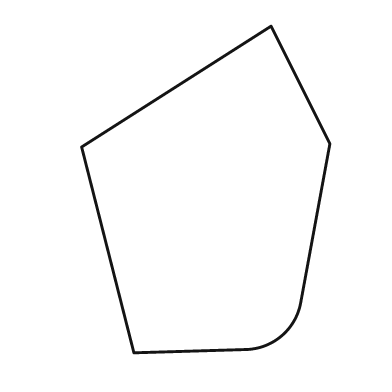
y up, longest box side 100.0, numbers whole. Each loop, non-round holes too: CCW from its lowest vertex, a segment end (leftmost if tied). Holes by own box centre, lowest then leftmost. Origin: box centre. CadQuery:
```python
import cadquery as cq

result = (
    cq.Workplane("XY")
    .moveTo(-22.0, -50.0)
    .lineTo(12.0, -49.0)
    .threePointArc((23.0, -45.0), (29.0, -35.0))
    .lineTo(38.0, 14.0)
    .lineTo(20.0, 50.0)
    .lineTo(-38.0, 13.0)
    .close()
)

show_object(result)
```